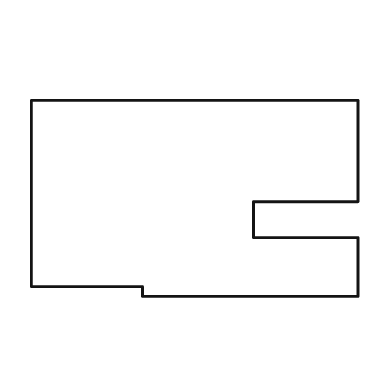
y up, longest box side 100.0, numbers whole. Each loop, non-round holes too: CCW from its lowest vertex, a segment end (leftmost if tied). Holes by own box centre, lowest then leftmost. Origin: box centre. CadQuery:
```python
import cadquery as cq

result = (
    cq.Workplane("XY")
    .moveTo(-16.0, -30.0)
    .lineTo(50.0, -30.0)
    .lineTo(50.0, -12.0)
    .lineTo(18.0, -12.0)
    .lineTo(18.0, -1.0)
    .lineTo(50.0, -1.0)
    .lineTo(50.0, 30.0)
    .lineTo(-50.0, 30.0)
    .lineTo(-50.0, -27.0)
    .lineTo(-16.0, -27.0)
    .close()
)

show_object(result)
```